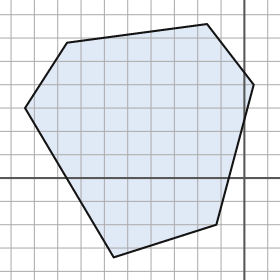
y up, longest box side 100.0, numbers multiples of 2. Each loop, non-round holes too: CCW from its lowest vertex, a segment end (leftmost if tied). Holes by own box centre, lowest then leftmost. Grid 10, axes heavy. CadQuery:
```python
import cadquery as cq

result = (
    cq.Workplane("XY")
    .moveTo(-56.0, -34.0)
    .lineTo(-12.0, -20.0)
    .lineTo(4.0, 40.0)
    .lineTo(-16.0, 66.0)
    .lineTo(-76.0, 58.0)
    .lineTo(-94.0, 30.0)
    .close()
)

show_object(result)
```